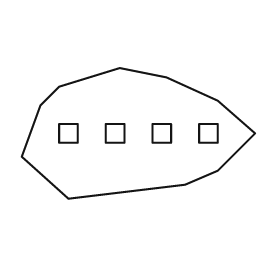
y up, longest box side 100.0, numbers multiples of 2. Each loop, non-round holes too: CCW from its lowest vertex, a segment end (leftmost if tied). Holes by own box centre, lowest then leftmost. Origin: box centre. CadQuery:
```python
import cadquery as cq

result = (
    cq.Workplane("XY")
    .moveTo(-30.0, -28.0)
    .lineTo(20.0, -22.0)
    .lineTo(34.0, -16.0)
    .lineTo(50.0, 0.0)
    .lineTo(34.0, 14.0)
    .lineTo(12.0, 24.0)
    .lineTo(-8.0, 28.0)
    .lineTo(-34.0, 20.0)
    .lineTo(-42.0, 12.0)
    .lineTo(-50.0, -10.0)
    .close()
    .moveTo(-34.0, -4.0)
    .lineTo(-26.0, -4.0)
    .lineTo(-26.0, 4.0)
    .lineTo(-34.0, 4.0)
    .close()
    .moveTo(-14.0, -4.0)
    .lineTo(-6.0, -4.0)
    .lineTo(-6.0, 4.0)
    .lineTo(-14.0, 4.0)
    .close()
    .moveTo(6.0, -4.0)
    .lineTo(14.0, -4.0)
    .lineTo(14.0, 4.0)
    .lineTo(6.0, 4.0)
    .close()
    .moveTo(26.0, -4.0)
    .lineTo(34.0, -4.0)
    .lineTo(34.0, 4.0)
    .lineTo(26.0, 4.0)
    .close()
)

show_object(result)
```